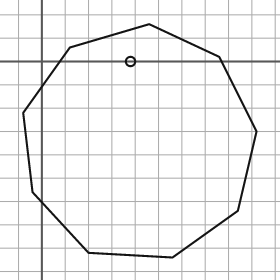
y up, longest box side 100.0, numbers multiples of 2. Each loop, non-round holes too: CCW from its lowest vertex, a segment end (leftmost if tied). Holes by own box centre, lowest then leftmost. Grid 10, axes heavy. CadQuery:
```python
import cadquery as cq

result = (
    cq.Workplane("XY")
    .moveTo(56.0, -84.0)
    .lineTo(84.0, -64.0)
    .lineTo(92.0, -30.0)
    .lineTo(76.0, 2.0)
    .lineTo(46.0, 16.0)
    .lineTo(12.0, 6.0)
    .lineTo(-8.0, -22.0)
    .lineTo(-4.0, -56.0)
    .lineTo(20.0, -82.0)
    .close()
    .moveTo(38.0, 0.0)
    .circle(2.0)
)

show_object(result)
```